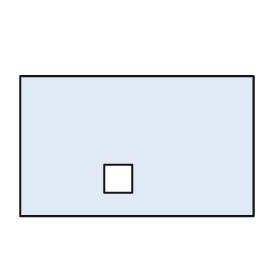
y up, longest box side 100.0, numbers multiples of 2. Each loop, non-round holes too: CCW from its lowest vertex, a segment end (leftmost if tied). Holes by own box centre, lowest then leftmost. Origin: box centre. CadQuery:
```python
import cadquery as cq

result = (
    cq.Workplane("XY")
    .moveTo(-50.0, -30.0)
    .lineTo(50.0, -30.0)
    .lineTo(50.0, 30.0)
    .lineTo(-50.0, 30.0)
    .close()
    .moveTo(-14.0, -20.0)
    .lineTo(-2.0, -20.0)
    .lineTo(-2.0, -8.0)
    .lineTo(-14.0, -8.0)
    .close()
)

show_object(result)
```